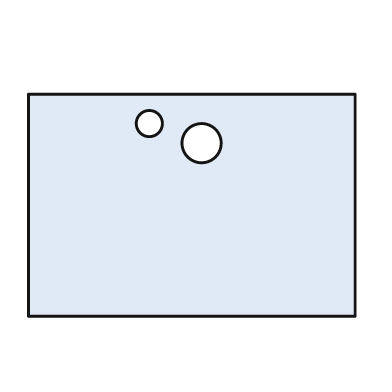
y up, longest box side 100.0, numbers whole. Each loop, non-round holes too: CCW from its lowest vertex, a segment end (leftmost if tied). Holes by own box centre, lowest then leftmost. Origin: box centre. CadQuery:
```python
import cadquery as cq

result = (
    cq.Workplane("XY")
    .moveTo(-50.0, -34.0)
    .lineTo(50.0, -34.0)
    .lineTo(50.0, 34.0)
    .lineTo(-50.0, 34.0)
    .close()
    .moveTo(3.0, 19.0)
    .circle(6.0)
    .moveTo(-13.0, 25.0)
    .circle(4.0)
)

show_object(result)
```